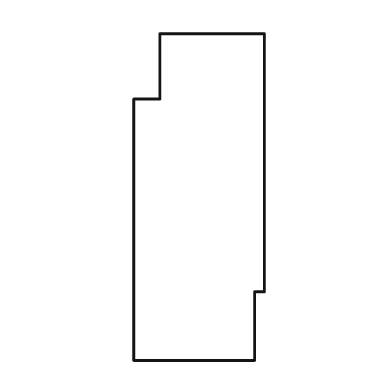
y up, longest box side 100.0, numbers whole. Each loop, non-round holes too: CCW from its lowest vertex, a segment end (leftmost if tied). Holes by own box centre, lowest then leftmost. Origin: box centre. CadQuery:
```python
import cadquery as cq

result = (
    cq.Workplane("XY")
    .moveTo(-20.0, -50.0)
    .lineTo(17.0, -50.0)
    .lineTo(17.0, -29.0)
    .lineTo(20.0, -29.0)
    .lineTo(20.0, 50.0)
    .lineTo(-12.0, 50.0)
    .lineTo(-12.0, 30.0)
    .lineTo(-20.0, 30.0)
    .close()
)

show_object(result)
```